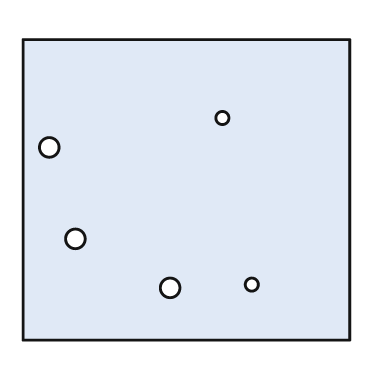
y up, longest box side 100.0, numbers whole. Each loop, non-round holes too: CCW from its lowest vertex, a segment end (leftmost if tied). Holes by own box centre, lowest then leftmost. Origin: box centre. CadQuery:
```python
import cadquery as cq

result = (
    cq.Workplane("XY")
    .moveTo(-50.0, -46.0)
    .lineTo(50.0, -46.0)
    .lineTo(50.0, 46.0)
    .lineTo(-50.0, 46.0)
    .close()
    .moveTo(-5.0, -30.0)
    .circle(3.0)
    .moveTo(20.0, -29.0)
    .circle(2.0)
    .moveTo(-34.0, -15.0)
    .circle(3.0)
    .moveTo(-42.0, 13.0)
    .circle(3.0)
    .moveTo(11.0, 22.0)
    .circle(2.0)
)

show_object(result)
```